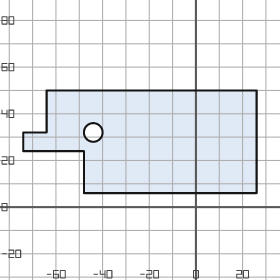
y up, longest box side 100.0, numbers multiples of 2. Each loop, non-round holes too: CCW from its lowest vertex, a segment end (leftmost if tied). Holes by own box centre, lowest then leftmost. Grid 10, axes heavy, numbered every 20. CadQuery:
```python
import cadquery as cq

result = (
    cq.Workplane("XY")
    .moveTo(-48.0, 6.0)
    .lineTo(26.0, 6.0)
    .lineTo(26.0, 50.0)
    .lineTo(-64.0, 50.0)
    .lineTo(-64.0, 32.0)
    .lineTo(-74.0, 32.0)
    .lineTo(-74.0, 24.0)
    .lineTo(-48.0, 24.0)
    .close()
    .moveTo(-44.0, 32.0)
    .circle(4.0)
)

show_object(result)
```